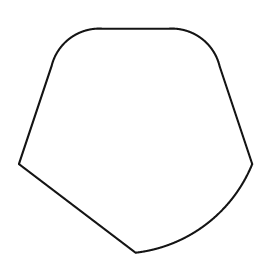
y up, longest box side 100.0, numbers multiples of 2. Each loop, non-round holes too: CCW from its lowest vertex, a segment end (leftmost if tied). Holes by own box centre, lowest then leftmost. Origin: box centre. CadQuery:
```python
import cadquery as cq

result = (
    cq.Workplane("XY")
    .moveTo(0.0, -48.0)
    .threePointArc((30.0, -36.0), (50.0, -10.0))
    .lineTo(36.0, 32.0)
    .threePointArc((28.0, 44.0), (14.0, 48.0))
    .lineTo(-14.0, 48.0)
    .threePointArc((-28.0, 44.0), (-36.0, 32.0))
    .lineTo(-50.0, -10.0)
    .close()
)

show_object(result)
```